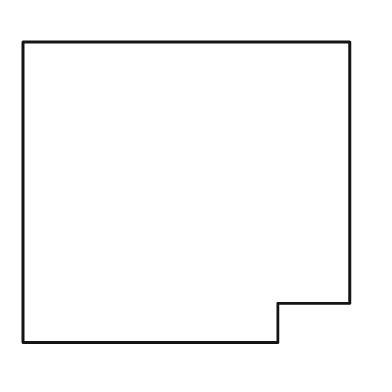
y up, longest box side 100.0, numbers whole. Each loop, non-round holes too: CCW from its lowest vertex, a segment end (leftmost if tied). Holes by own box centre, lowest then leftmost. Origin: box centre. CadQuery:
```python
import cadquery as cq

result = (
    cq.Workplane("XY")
    .moveTo(-50.0, -46.0)
    .lineTo(28.0, -46.0)
    .lineTo(28.0, -34.0)
    .lineTo(50.0, -34.0)
    .lineTo(50.0, 46.0)
    .lineTo(-50.0, 46.0)
    .close()
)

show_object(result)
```